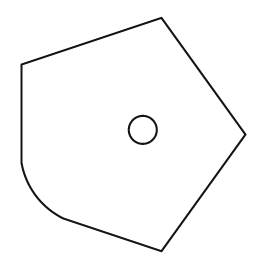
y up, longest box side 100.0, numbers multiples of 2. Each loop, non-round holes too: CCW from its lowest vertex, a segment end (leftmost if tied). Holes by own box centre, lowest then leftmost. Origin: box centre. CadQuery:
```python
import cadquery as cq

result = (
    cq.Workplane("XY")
    .moveTo(12.0, -50.0)
    .lineTo(48.0, 0.0)
    .lineTo(12.0, 50.0)
    .lineTo(-48.0, 30.0)
    .lineTo(-48.0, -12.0)
    .threePointArc((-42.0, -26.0), (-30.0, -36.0))
    .close()
    .moveTo(4.0, 2.0)
    .circle(6.0)
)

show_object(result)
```